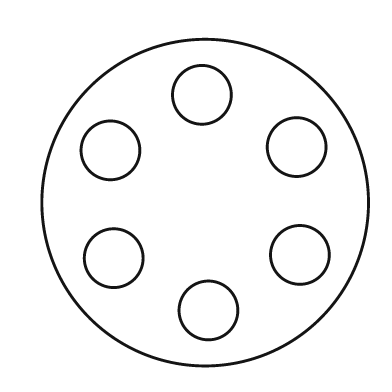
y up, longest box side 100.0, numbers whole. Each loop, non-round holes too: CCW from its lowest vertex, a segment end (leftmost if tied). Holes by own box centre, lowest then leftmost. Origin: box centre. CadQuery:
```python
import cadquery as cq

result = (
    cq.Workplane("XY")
    .moveTo(0.0, 0.0)
    .circle(50.0)
    .moveTo(1.0, -33.0)
    .circle(9.0)
    .moveTo(-28.0, -17.0)
    .circle(9.0)
    .moveTo(29.0, -16.0)
    .circle(9.0)
    .moveTo(-29.0, 16.0)
    .circle(9.0)
    .moveTo(28.0, 17.0)
    .circle(9.0)
    .moveTo(-1.0, 33.0)
    .circle(9.0)
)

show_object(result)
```